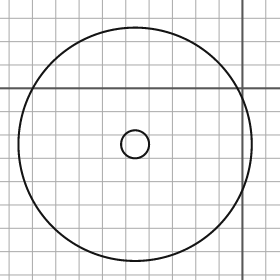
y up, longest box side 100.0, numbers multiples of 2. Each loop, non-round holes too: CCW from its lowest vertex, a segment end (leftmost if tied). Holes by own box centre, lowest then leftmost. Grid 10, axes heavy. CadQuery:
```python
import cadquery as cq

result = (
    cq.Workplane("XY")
    .moveTo(-46.0, -24.0)
    .circle(50.0)
    .moveTo(-46.0, -24.0)
    .circle(6.0)
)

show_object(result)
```